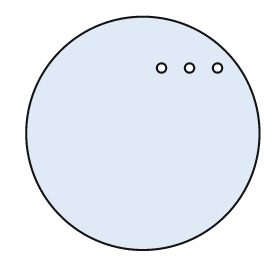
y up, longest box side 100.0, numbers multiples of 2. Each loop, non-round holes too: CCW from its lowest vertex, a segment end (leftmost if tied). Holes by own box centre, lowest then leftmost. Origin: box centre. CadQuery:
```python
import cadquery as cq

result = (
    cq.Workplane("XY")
    .moveTo(0.0, 0.0)
    .circle(50.0)
    .moveTo(8.0, 28.0)
    .circle(2.0)
    .moveTo(20.0, 28.0)
    .circle(2.0)
    .moveTo(32.0, 28.0)
    .circle(2.0)
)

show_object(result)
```